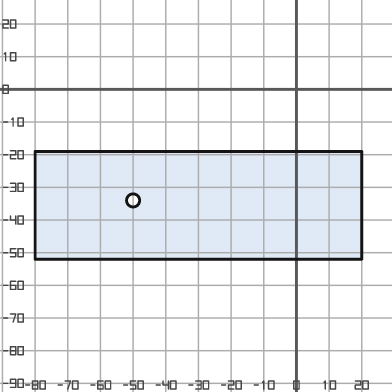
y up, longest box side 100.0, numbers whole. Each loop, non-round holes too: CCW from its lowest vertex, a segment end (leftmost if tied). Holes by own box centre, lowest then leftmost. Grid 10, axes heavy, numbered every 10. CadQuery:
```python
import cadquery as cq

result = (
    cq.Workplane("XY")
    .moveTo(-80.0, -52.0)
    .lineTo(20.0, -52.0)
    .lineTo(20.0, -19.0)
    .lineTo(-80.0, -19.0)
    .close()
    .moveTo(-50.0, -34.0)
    .circle(2.0)
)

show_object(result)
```